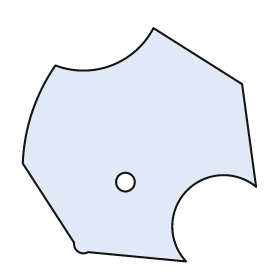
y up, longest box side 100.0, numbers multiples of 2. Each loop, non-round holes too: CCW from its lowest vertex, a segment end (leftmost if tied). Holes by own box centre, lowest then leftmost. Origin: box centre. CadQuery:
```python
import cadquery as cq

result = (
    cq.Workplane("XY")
    .moveTo(20.0, -50.0)
    .threePointArc((20.0, -20.0), (50.0, -18.0))
    .lineTo(44.0, 26.0)
    .lineTo(6.0, 50.0)
    .threePointArc((-12.0, 34.0), (-36.0, 34.0))
    .threePointArc((-46.0, 14.0), (-50.0, -8.0))
    .lineTo(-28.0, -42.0)
    .threePointArc((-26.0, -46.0), (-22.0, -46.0))
    .close()
    .moveTo(-6.0, -16.0)
    .circle(4.0)
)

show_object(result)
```